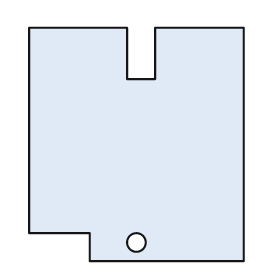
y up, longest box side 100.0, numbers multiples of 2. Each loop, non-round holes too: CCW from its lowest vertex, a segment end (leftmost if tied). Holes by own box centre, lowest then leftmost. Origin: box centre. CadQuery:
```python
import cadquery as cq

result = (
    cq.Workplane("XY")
    .moveTo(-20.0, -50.0)
    .lineTo(46.0, -50.0)
    .lineTo(46.0, 50.0)
    .lineTo(8.0, 50.0)
    .lineTo(8.0, 28.0)
    .lineTo(-4.0, 28.0)
    .lineTo(-4.0, 50.0)
    .lineTo(-46.0, 50.0)
    .lineTo(-46.0, -38.0)
    .lineTo(-20.0, -38.0)
    .close()
    .moveTo(0.0, -42.0)
    .circle(4.0)
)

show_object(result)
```